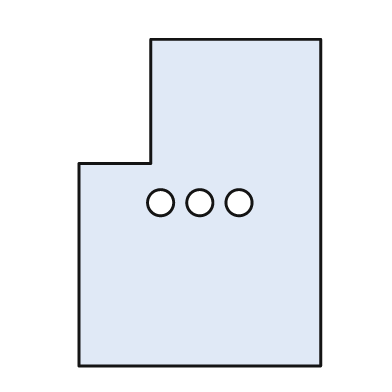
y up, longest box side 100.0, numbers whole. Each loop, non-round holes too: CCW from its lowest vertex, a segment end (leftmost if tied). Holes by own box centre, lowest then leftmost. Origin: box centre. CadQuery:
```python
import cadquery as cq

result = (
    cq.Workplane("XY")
    .moveTo(-37.0, -50.0)
    .lineTo(37.0, -50.0)
    .lineTo(37.0, 50.0)
    .lineTo(-15.0, 50.0)
    .lineTo(-15.0, 12.0)
    .lineTo(-37.0, 12.0)
    .close()
    .moveTo(-12.0, 0.0)
    .circle(4.0)
    .moveTo(0.0, 0.0)
    .circle(4.0)
    .moveTo(12.0, 0.0)
    .circle(4.0)
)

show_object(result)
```